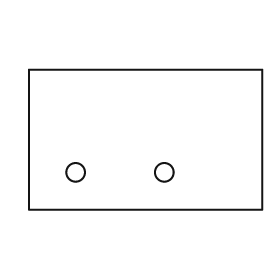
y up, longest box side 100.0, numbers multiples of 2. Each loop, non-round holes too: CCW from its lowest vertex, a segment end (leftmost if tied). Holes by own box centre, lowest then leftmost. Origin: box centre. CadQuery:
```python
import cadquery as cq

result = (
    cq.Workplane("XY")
    .moveTo(-50.0, -30.0)
    .lineTo(50.0, -30.0)
    .lineTo(50.0, 30.0)
    .lineTo(-50.0, 30.0)
    .close()
    .moveTo(-30.0, -14.0)
    .circle(4.0)
    .moveTo(8.0, -14.0)
    .circle(4.0)
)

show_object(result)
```